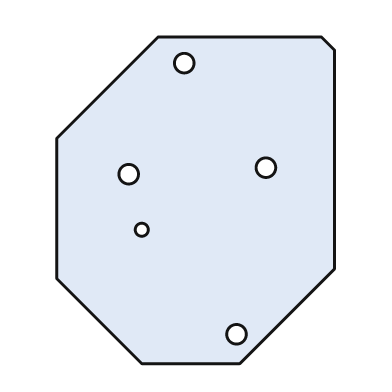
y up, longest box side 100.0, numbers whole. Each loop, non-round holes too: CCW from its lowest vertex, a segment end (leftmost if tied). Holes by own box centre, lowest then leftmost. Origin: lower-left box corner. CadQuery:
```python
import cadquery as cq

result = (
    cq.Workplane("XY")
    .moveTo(26.0, 0.0)
    .lineTo(56.0, 0.0)
    .lineTo(85.0, 29.0)
    .lineTo(85.0, 96.0)
    .lineTo(81.0, 100.0)
    .lineTo(31.0, 100.0)
    .lineTo(0.0, 69.0)
    .lineTo(0.0, 26.0)
    .close()
    .moveTo(55.0, 9.0)
    .circle(3.0)
    .moveTo(26.0, 41.0)
    .circle(2.0)
    .moveTo(22.0, 58.0)
    .circle(3.0)
    .moveTo(64.0, 60.0)
    .circle(3.0)
    .moveTo(39.0, 92.0)
    .circle(3.0)
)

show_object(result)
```